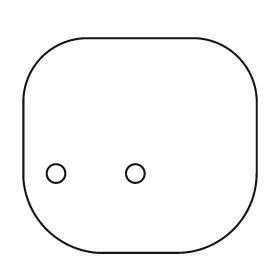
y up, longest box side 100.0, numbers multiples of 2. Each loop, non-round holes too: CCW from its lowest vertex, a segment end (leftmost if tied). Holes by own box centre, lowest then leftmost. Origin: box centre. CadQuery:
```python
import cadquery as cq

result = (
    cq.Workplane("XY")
    .moveTo(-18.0, -46.0)
    .lineTo(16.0, -46.0)
    .threePointArc((40.0, -36.0), (50.0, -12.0))
    .lineTo(50.0, 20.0)
    .threePointArc((42.0, 38.0), (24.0, 46.0))
    .lineTo(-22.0, 46.0)
    .threePointArc((-42.0, 38.0), (-50.0, 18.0))
    .lineTo(-50.0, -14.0)
    .threePointArc((-40.0, -36.0), (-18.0, -46.0))
    .close()
    .moveTo(-36.0, -12.0)
    .circle(4.0)
    .moveTo(-2.0, -12.0)
    .circle(4.0)
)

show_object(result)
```